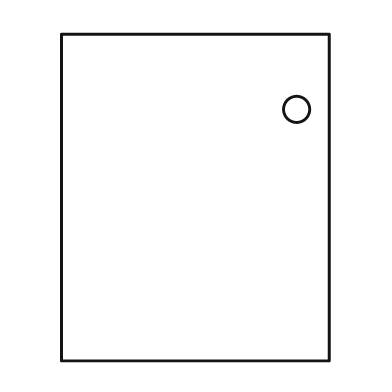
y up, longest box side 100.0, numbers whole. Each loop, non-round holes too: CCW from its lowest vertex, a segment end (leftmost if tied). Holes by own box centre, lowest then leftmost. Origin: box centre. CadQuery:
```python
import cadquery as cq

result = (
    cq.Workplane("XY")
    .moveTo(-41.0, -50.0)
    .lineTo(41.0, -50.0)
    .lineTo(41.0, 50.0)
    .lineTo(-41.0, 50.0)
    .close()
    .moveTo(31.0, 27.0)
    .circle(4.0)
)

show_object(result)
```